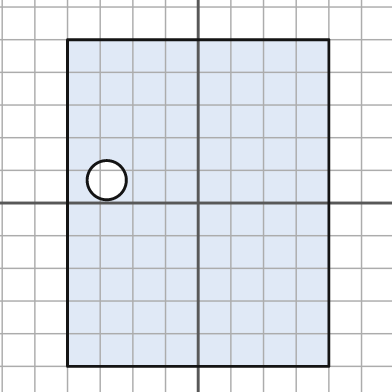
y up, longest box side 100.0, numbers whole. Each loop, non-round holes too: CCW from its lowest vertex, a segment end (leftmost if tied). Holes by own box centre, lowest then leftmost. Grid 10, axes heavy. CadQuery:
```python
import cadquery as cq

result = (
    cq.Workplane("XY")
    .moveTo(-40.0, -50.0)
    .lineTo(40.0, -50.0)
    .lineTo(40.0, 50.0)
    .lineTo(-40.0, 50.0)
    .close()
    .moveTo(-28.0, 7.0)
    .circle(6.0)
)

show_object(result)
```